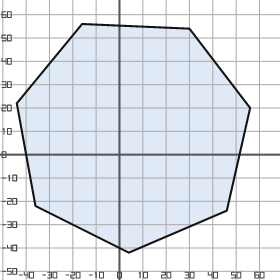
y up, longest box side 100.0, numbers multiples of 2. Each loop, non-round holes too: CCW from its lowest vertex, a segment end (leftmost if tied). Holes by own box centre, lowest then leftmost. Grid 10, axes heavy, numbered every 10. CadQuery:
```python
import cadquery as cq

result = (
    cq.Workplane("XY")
    .moveTo(4.0, -42.0)
    .lineTo(46.0, -24.0)
    .lineTo(56.0, 20.0)
    .lineTo(30.0, 54.0)
    .lineTo(-16.0, 56.0)
    .lineTo(-44.0, 22.0)
    .lineTo(-36.0, -22.0)
    .close()
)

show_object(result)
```